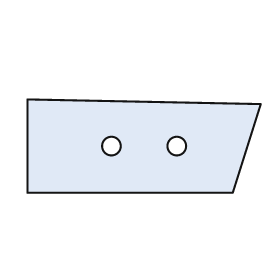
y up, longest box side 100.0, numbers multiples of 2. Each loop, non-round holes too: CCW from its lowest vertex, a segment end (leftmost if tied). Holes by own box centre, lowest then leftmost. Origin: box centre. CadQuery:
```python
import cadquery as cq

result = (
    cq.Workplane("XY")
    .moveTo(-50.0, -20.0)
    .lineTo(38.0, -20.0)
    .lineTo(50.0, 18.0)
    .lineTo(-50.0, 20.0)
    .close()
    .moveTo(-14.0, 0.0)
    .circle(4.0)
    .moveTo(14.0, 0.0)
    .circle(4.0)
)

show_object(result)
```